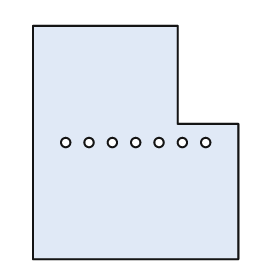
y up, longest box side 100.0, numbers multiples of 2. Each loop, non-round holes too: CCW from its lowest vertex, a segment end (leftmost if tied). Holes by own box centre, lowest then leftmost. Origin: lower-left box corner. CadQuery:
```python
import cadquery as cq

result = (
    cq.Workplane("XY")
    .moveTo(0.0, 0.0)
    .lineTo(88.0, 0.0)
    .lineTo(88.0, 58.0)
    .lineTo(62.0, 58.0)
    .lineTo(62.0, 100.0)
    .lineTo(0.0, 100.0)
    .close()
    .moveTo(14.0, 50.0)
    .circle(2.0)
    .moveTo(24.0, 50.0)
    .circle(2.0)
    .moveTo(34.0, 50.0)
    .circle(2.0)
    .moveTo(44.0, 50.0)
    .circle(2.0)
    .moveTo(54.0, 50.0)
    .circle(2.0)
    .moveTo(64.0, 50.0)
    .circle(2.0)
    .moveTo(74.0, 50.0)
    .circle(2.0)
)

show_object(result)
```